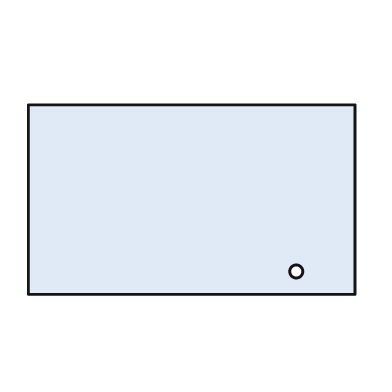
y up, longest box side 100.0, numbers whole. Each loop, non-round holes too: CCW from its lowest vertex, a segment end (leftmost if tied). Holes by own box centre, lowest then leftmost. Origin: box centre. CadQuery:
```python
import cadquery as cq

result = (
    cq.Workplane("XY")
    .moveTo(-50.0, -29.0)
    .lineTo(50.0, -29.0)
    .lineTo(50.0, 29.0)
    .lineTo(-50.0, 29.0)
    .close()
    .moveTo(32.0, -22.0)
    .circle(2.0)
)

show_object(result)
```